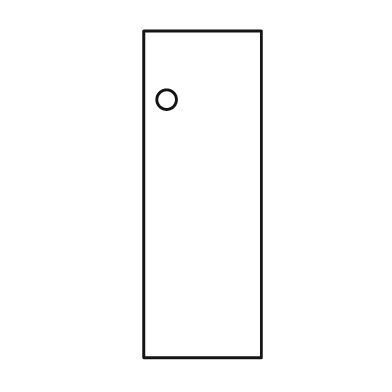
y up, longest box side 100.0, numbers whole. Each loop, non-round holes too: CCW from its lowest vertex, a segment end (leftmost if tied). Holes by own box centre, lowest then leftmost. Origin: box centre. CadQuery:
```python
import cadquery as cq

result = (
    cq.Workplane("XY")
    .moveTo(-18.0, -50.0)
    .lineTo(18.0, -50.0)
    .lineTo(18.0, 50.0)
    .lineTo(-18.0, 50.0)
    .close()
    .moveTo(-11.0, 29.0)
    .circle(3.0)
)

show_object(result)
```